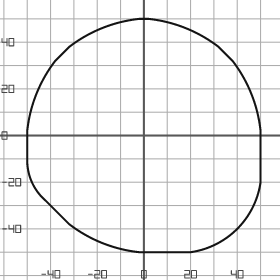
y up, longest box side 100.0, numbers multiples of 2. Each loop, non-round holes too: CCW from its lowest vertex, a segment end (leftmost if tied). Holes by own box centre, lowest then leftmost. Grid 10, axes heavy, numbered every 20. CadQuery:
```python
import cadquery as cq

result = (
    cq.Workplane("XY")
    .moveTo(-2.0, -50.0)
    .lineTo(20.0, -50.0)
    .threePointArc((40.0, -40.0), (50.0, -20.0))
    .lineTo(50.0, 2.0)
    .threePointArc((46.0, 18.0), (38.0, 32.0))
    .lineTo(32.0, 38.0)
    .threePointArc((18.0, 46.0), (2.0, 50.0))
    .lineTo(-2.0, 50.0)
    .threePointArc((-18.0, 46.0), (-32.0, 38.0))
    .lineTo(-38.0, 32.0)
    .threePointArc((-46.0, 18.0), (-50.0, 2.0))
    .lineTo(-50.0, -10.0)
    .threePointArc((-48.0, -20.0), (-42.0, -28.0))
    .lineTo(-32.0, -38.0)
    .threePointArc((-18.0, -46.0), (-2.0, -50.0))
    .close()
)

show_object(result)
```